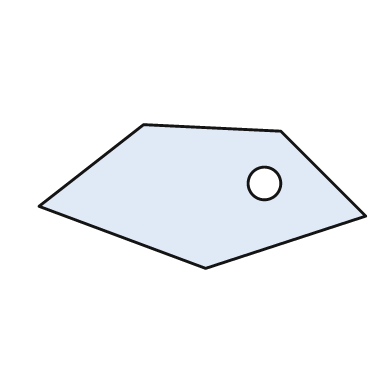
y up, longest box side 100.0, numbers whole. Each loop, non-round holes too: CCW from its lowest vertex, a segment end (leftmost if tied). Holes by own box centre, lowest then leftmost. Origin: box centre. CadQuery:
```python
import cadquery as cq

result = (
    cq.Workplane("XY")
    .moveTo(1.0, -22.0)
    .lineTo(50.0, -6.0)
    .lineTo(24.0, 20.0)
    .lineTo(-18.0, 22.0)
    .lineTo(-50.0, -3.0)
    .close()
    .moveTo(19.0, 4.0)
    .circle(5.0)
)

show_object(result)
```